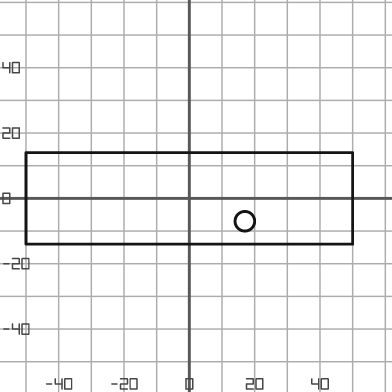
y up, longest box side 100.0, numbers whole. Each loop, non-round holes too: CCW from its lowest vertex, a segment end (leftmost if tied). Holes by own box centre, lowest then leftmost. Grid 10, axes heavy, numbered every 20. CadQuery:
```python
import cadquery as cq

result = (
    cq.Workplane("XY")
    .moveTo(-50.0, -14.0)
    .lineTo(50.0, -14.0)
    .lineTo(50.0, 14.0)
    .lineTo(-50.0, 14.0)
    .close()
    .moveTo(17.0, -7.0)
    .circle(3.0)
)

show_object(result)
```